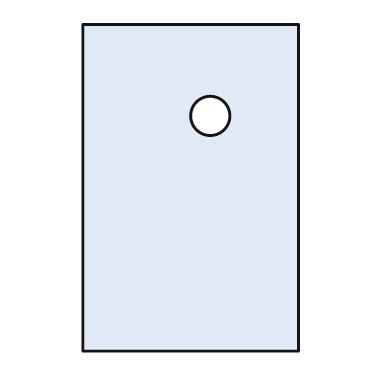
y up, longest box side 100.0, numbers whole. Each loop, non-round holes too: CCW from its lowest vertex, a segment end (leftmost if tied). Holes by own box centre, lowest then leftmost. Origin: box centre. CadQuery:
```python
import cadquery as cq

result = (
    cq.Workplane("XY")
    .moveTo(-33.0, -50.0)
    .lineTo(33.0, -50.0)
    .lineTo(33.0, 50.0)
    .lineTo(-33.0, 50.0)
    .close()
    .moveTo(6.0, 22.0)
    .circle(6.0)
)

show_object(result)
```